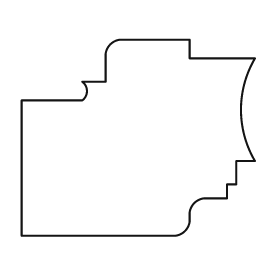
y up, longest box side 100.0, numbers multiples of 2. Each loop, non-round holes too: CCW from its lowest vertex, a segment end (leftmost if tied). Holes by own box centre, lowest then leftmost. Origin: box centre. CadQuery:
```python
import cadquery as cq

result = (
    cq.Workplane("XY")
    .moveTo(-50.0, -42.0)
    .lineTo(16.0, -42.0)
    .threePointArc((20.0, -40.0), (22.0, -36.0))
    .lineTo(22.0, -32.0)
    .threePointArc((24.0, -28.0), (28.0, -26.0))
    .lineTo(38.0, -26.0)
    .lineTo(38.0, -20.0)
    .lineTo(42.0, -20.0)
    .lineTo(42.0, -10.0)
    .lineTo(50.0, -10.0)
    .threePointArc((44.0, 12.0), (50.0, 34.0))
    .lineTo(22.0, 34.0)
    .lineTo(22.0, 42.0)
    .lineTo(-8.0, 42.0)
    .threePointArc((-12.0, 40.0), (-14.0, 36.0))
    .lineTo(-14.0, 24.0)
    .lineTo(-24.0, 24.0)
    .threePointArc((-22.0, 20.0), (-24.0, 16.0))
    .lineTo(-50.0, 16.0)
    .close()
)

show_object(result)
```